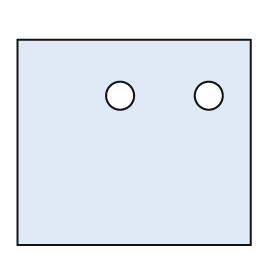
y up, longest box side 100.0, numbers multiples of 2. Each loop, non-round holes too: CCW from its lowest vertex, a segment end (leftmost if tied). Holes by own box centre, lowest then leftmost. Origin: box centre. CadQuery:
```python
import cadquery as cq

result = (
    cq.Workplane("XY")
    .moveTo(-50.0, -44.0)
    .lineTo(50.0, -44.0)
    .lineTo(50.0, 44.0)
    .lineTo(-50.0, 44.0)
    .close()
    .moveTo(-6.0, 20.0)
    .circle(6.0)
    .moveTo(32.0, 20.0)
    .circle(6.0)
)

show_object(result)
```